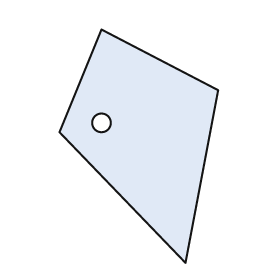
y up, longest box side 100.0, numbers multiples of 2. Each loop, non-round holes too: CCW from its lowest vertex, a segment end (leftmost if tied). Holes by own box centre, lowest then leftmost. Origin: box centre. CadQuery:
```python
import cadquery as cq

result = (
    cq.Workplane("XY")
    .moveTo(20.0, -50.0)
    .lineTo(34.0, 24.0)
    .lineTo(-16.0, 50.0)
    .lineTo(-34.0, 6.0)
    .close()
    .moveTo(-16.0, 10.0)
    .circle(4.0)
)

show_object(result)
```